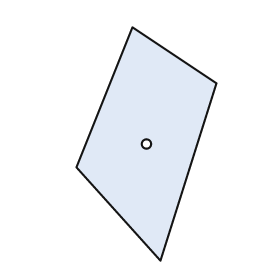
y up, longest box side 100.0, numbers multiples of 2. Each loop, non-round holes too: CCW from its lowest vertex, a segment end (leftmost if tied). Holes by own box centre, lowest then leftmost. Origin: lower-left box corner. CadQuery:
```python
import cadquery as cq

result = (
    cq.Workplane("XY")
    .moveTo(36.0, 0.0)
    .lineTo(60.0, 76.0)
    .lineTo(24.0, 100.0)
    .lineTo(0.0, 40.0)
    .close()
    .moveTo(30.0, 50.0)
    .circle(2.0)
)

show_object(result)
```